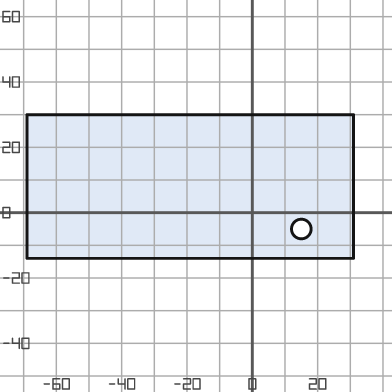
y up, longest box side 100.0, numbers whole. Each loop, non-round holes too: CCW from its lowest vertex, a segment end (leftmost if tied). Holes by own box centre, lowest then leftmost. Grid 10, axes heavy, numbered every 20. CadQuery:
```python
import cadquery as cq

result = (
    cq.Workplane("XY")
    .moveTo(-69.0, -14.0)
    .lineTo(31.0, -14.0)
    .lineTo(31.0, 30.0)
    .lineTo(-69.0, 30.0)
    .close()
    .moveTo(15.0, -5.0)
    .circle(3.0)
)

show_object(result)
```